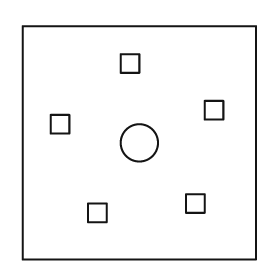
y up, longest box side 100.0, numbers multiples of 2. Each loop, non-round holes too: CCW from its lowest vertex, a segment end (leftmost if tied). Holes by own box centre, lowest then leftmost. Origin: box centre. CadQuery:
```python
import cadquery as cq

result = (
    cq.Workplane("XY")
    .moveTo(-50.0, -50.0)
    .lineTo(50.0, -50.0)
    .lineTo(50.0, 50.0)
    .lineTo(-50.0, 50.0)
    .close()
    .moveTo(-22.0, -34.0)
    .lineTo(-14.0, -34.0)
    .lineTo(-14.0, -26.0)
    .lineTo(-22.0, -26.0)
    .close()
    .moveTo(20.0, -30.0)
    .lineTo(28.0, -30.0)
    .lineTo(28.0, -22.0)
    .lineTo(20.0, -22.0)
    .close()
    .moveTo(0.0, 0.0)
    .circle(8.0)
    .moveTo(-38.0, 4.0)
    .lineTo(-30.0, 4.0)
    .lineTo(-30.0, 12.0)
    .lineTo(-38.0, 12.0)
    .close()
    .moveTo(28.0, 10.0)
    .lineTo(36.0, 10.0)
    .lineTo(36.0, 18.0)
    .lineTo(28.0, 18.0)
    .close()
    .moveTo(-8.0, 30.0)
    .lineTo(0.0, 30.0)
    .lineTo(0.0, 38.0)
    .lineTo(-8.0, 38.0)
    .close()
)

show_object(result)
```